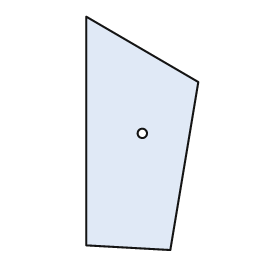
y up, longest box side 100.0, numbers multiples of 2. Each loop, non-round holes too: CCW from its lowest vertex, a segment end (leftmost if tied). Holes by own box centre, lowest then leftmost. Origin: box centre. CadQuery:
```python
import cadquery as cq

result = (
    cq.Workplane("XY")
    .moveTo(12.0, -50.0)
    .lineTo(24.0, 22.0)
    .lineTo(-24.0, 50.0)
    .lineTo(-24.0, -48.0)
    .close()
    .moveTo(0.0, 0.0)
    .circle(2.0)
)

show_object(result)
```